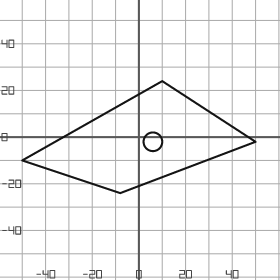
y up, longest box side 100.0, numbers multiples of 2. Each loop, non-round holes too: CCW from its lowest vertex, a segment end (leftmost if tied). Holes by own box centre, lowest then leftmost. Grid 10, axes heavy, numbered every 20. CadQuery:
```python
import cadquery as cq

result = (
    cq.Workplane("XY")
    .moveTo(-8.0, -24.0)
    .lineTo(50.0, -2.0)
    .lineTo(10.0, 24.0)
    .lineTo(-50.0, -10.0)
    .close()
    .moveTo(6.0, -2.0)
    .circle(4.0)
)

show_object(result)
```